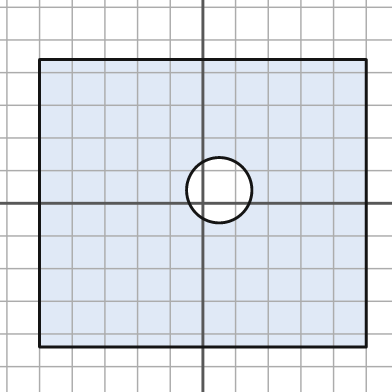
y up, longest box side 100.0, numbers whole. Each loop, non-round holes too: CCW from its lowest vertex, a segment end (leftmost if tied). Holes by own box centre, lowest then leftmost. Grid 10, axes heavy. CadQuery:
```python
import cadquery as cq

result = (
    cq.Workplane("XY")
    .moveTo(-50.0, -44.0)
    .lineTo(50.0, -44.0)
    .lineTo(50.0, 44.0)
    .lineTo(-50.0, 44.0)
    .close()
    .moveTo(5.0, 4.0)
    .circle(10.0)
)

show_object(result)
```